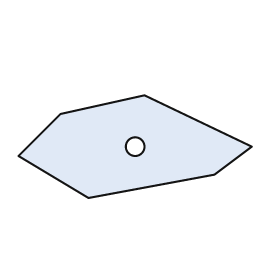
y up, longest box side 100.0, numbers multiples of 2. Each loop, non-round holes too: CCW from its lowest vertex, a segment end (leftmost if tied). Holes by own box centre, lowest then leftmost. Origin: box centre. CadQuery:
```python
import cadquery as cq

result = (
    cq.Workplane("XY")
    .moveTo(-20.0, -22.0)
    .lineTo(34.0, -12.0)
    .lineTo(50.0, 0.0)
    .lineTo(4.0, 22.0)
    .lineTo(-32.0, 14.0)
    .lineTo(-50.0, -4.0)
    .close()
    .moveTo(0.0, 0.0)
    .circle(4.0)
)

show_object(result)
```